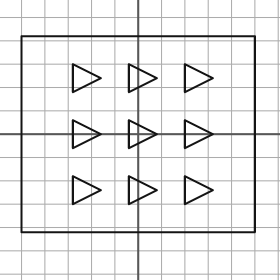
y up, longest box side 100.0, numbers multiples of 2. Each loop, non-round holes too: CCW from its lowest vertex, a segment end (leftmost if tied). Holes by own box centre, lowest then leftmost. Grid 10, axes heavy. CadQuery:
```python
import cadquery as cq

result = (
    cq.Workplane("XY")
    .moveTo(-50.0, -42.0)
    .lineTo(50.0, -42.0)
    .lineTo(50.0, 42.0)
    .lineTo(-50.0, 42.0)
    .close()
    .moveTo(-28.0, -30.0)
    .lineTo(-16.0, -24.0)
    .lineTo(-28.0, -18.0)
    .close()
    .moveTo(-4.0, -30.0)
    .lineTo(8.0, -24.0)
    .lineTo(-4.0, -18.0)
    .close()
    .moveTo(20.0, -30.0)
    .lineTo(32.0, -24.0)
    .lineTo(20.0, -18.0)
    .close()
    .moveTo(-28.0, -6.0)
    .lineTo(-16.0, 0.0)
    .lineTo(-28.0, 6.0)
    .close()
    .moveTo(-4.0, -6.0)
    .lineTo(8.0, 0.0)
    .lineTo(-4.0, 6.0)
    .close()
    .moveTo(20.0, -6.0)
    .lineTo(32.0, 0.0)
    .lineTo(20.0, 6.0)
    .close()
    .moveTo(-28.0, 18.0)
    .lineTo(-16.0, 24.0)
    .lineTo(-28.0, 30.0)
    .close()
    .moveTo(-4.0, 18.0)
    .lineTo(8.0, 24.0)
    .lineTo(-4.0, 30.0)
    .close()
    .moveTo(20.0, 18.0)
    .lineTo(32.0, 24.0)
    .lineTo(20.0, 30.0)
    .close()
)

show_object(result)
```